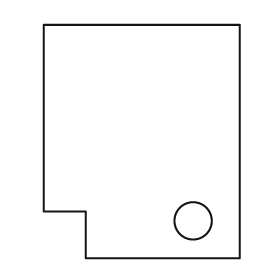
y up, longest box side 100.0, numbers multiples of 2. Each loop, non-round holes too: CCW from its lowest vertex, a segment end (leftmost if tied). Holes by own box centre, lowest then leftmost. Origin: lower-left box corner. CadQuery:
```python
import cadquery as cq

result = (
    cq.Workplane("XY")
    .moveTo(18.0, 0.0)
    .lineTo(84.0, 0.0)
    .lineTo(84.0, 100.0)
    .lineTo(0.0, 100.0)
    .lineTo(0.0, 20.0)
    .lineTo(18.0, 20.0)
    .close()
    .moveTo(64.0, 16.0)
    .circle(8.0)
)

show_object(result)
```